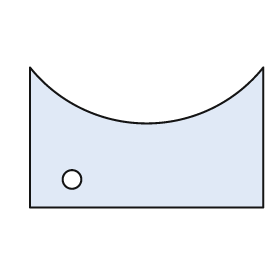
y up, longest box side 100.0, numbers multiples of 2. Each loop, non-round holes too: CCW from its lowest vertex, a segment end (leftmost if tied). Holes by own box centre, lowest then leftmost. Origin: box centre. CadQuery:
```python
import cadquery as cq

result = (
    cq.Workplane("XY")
    .moveTo(-50.0, -30.0)
    .lineTo(50.0, -30.0)
    .lineTo(50.0, 30.0)
    .threePointArc((0.0, 6.0), (-50.0, 30.0))
    .close()
    .moveTo(-32.0, -18.0)
    .circle(4.0)
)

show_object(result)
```